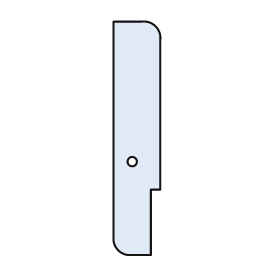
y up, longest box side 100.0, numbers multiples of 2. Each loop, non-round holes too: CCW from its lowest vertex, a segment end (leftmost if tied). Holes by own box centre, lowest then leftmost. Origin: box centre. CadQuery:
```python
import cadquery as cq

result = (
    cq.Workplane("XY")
    .moveTo(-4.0, -50.0)
    .lineTo(6.0, -50.0)
    .lineTo(6.0, -22.0)
    .lineTo(10.0, -22.0)
    .lineTo(10.0, 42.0)
    .threePointArc((8.0, 48.0), (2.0, 50.0))
    .lineTo(-10.0, 50.0)
    .lineTo(-10.0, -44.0)
    .threePointArc((-8.0, -48.0), (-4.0, -50.0))
    .close()
    .moveTo(-2.0, -10.0)
    .circle(2.0)
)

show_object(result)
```